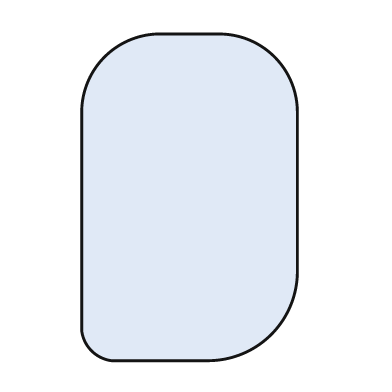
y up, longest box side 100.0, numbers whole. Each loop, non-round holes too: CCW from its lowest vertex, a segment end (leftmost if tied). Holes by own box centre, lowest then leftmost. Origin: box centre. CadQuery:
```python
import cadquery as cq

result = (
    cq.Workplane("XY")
    .moveTo(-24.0, -50.0)
    .lineTo(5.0, -50.0)
    .threePointArc((25.0, -42.0), (33.0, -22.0))
    .lineTo(33.0, 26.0)
    .threePointArc((26.0, 43.0), (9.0, 50.0))
    .lineTo(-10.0, 50.0)
    .threePointArc((-26.0, 43.0), (-33.0, 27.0))
    .lineTo(-33.0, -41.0)
    .threePointArc((-30.0, -47.0), (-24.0, -50.0))
    .close()
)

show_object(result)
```